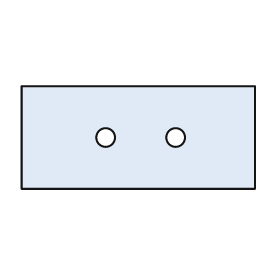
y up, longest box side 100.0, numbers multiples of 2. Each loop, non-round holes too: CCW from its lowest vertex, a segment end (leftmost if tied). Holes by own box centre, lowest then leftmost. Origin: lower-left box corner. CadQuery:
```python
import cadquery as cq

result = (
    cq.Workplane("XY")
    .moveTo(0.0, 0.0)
    .lineTo(100.0, 0.0)
    .lineTo(100.0, 44.0)
    .lineTo(0.0, 44.0)
    .close()
    .moveTo(36.0, 22.0)
    .circle(4.0)
    .moveTo(66.0, 22.0)
    .circle(4.0)
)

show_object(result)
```